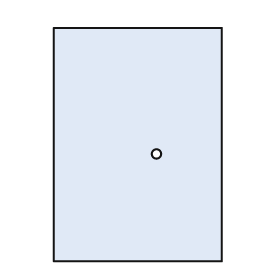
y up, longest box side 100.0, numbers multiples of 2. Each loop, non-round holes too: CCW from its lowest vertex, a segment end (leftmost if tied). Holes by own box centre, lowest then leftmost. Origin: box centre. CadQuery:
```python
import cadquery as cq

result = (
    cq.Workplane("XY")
    .moveTo(-36.0, -50.0)
    .lineTo(36.0, -50.0)
    .lineTo(36.0, 50.0)
    .lineTo(-36.0, 50.0)
    .close()
    .moveTo(8.0, -4.0)
    .circle(2.0)
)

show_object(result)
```